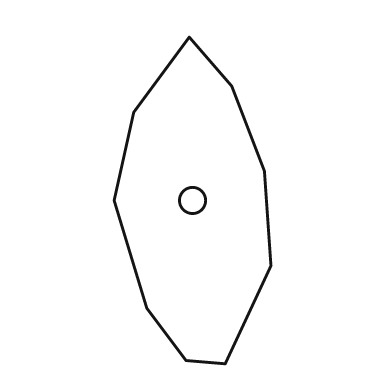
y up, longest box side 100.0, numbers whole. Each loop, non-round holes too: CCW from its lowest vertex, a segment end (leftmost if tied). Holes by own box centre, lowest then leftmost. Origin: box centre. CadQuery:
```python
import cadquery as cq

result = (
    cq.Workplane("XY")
    .moveTo(10.0, -50.0)
    .lineTo(24.0, -20.0)
    .lineTo(22.0, 9.0)
    .lineTo(12.0, 35.0)
    .lineTo(-1.0, 50.0)
    .lineTo(-18.0, 27.0)
    .lineTo(-24.0, 0.0)
    .lineTo(-14.0, -33.0)
    .lineTo(-2.0, -49.0)
    .close()
    .moveTo(0.0, 0.0)
    .circle(4.0)
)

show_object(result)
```